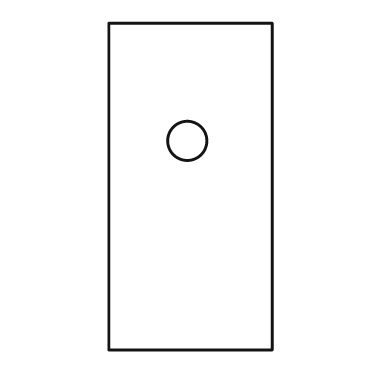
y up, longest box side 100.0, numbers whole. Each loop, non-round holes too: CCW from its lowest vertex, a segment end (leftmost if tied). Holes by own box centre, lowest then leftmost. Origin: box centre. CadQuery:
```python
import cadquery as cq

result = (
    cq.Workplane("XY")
    .moveTo(-25.0, -50.0)
    .lineTo(25.0, -50.0)
    .lineTo(25.0, 50.0)
    .lineTo(-25.0, 50.0)
    .close()
    .moveTo(-1.0, 14.0)
    .circle(6.0)
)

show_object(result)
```